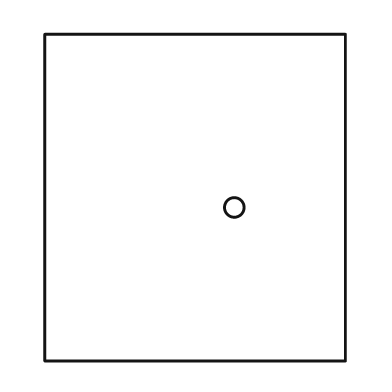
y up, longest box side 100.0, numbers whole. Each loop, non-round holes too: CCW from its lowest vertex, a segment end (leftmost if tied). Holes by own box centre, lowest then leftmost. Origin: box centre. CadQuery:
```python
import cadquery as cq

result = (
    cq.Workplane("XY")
    .moveTo(-46.0, -50.0)
    .lineTo(46.0, -50.0)
    .lineTo(46.0, 50.0)
    .lineTo(-46.0, 50.0)
    .close()
    .moveTo(12.0, -3.0)
    .circle(3.0)
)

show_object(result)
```